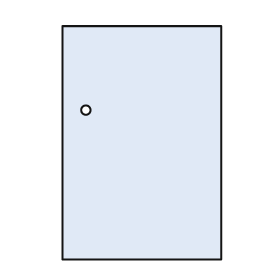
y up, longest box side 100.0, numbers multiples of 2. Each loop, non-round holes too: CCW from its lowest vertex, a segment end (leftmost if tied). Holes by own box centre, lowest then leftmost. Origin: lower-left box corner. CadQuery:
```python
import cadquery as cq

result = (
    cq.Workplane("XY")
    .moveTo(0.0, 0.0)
    .lineTo(68.0, 0.0)
    .lineTo(68.0, 100.0)
    .lineTo(0.0, 100.0)
    .close()
    .moveTo(10.0, 64.0)
    .circle(2.0)
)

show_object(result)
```